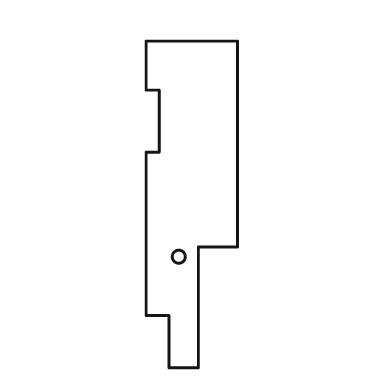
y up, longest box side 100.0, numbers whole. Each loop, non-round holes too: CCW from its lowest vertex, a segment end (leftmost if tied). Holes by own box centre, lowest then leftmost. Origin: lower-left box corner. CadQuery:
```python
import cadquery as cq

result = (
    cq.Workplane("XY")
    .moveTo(7.0, 0.0)
    .lineTo(16.0, 0.0)
    .lineTo(16.0, 37.0)
    .lineTo(28.0, 37.0)
    .lineTo(28.0, 100.0)
    .lineTo(0.0, 100.0)
    .lineTo(0.0, 85.0)
    .lineTo(4.0, 85.0)
    .lineTo(4.0, 66.0)
    .lineTo(0.0, 66.0)
    .lineTo(0.0, 16.0)
    .lineTo(7.0, 16.0)
    .close()
    .moveTo(10.0, 34.0)
    .circle(2.0)
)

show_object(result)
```